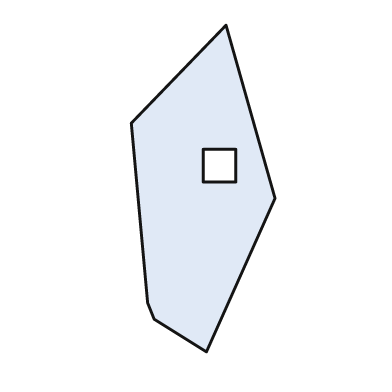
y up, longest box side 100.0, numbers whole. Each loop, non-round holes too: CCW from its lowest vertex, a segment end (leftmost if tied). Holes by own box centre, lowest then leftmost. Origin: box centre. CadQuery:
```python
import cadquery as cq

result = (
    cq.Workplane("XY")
    .moveTo(1.0, -50.0)
    .lineTo(22.0, -3.0)
    .lineTo(7.0, 50.0)
    .lineTo(-22.0, 20.0)
    .lineTo(-17.0, -35.0)
    .lineTo(-15.0, -40.0)
    .close()
    .moveTo(0.0, 2.0)
    .lineTo(10.0, 2.0)
    .lineTo(10.0, 12.0)
    .lineTo(0.0, 12.0)
    .close()
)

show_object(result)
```